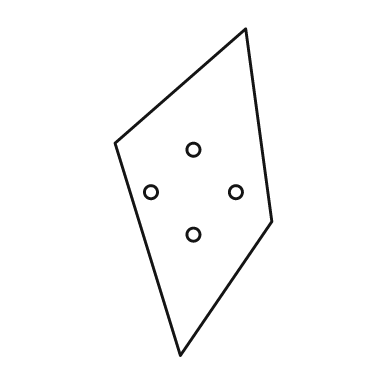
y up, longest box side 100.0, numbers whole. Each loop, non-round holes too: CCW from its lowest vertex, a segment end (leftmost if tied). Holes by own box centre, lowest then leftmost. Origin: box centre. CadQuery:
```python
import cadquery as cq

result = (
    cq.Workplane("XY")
    .moveTo(-4.0, -50.0)
    .lineTo(24.0, -9.0)
    .lineTo(16.0, 50.0)
    .lineTo(-24.0, 15.0)
    .close()
    .moveTo(0.0, -13.0)
    .circle(2.0)
    .moveTo(-13.0, 0.0)
    .circle(2.0)
    .moveTo(13.0, 0.0)
    .circle(2.0)
    .moveTo(0.0, 13.0)
    .circle(2.0)
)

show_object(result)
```